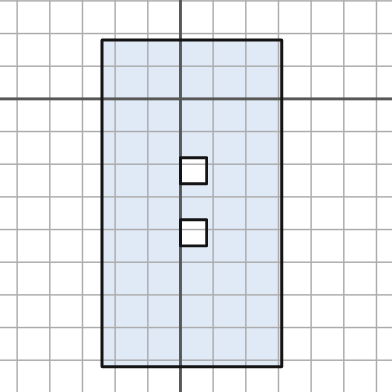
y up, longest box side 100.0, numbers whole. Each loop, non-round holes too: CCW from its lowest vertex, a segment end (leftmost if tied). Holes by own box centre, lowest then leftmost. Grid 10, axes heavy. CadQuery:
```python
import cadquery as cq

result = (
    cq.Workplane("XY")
    .moveTo(-24.0, -82.0)
    .lineTo(31.0, -82.0)
    .lineTo(31.0, 18.0)
    .lineTo(-24.0, 18.0)
    .close()
    .moveTo(0.0, -45.0)
    .lineTo(8.0, -45.0)
    .lineTo(8.0, -37.0)
    .lineTo(0.0, -37.0)
    .close()
    .moveTo(0.0, -26.0)
    .lineTo(8.0, -26.0)
    .lineTo(8.0, -18.0)
    .lineTo(0.0, -18.0)
    .close()
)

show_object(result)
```